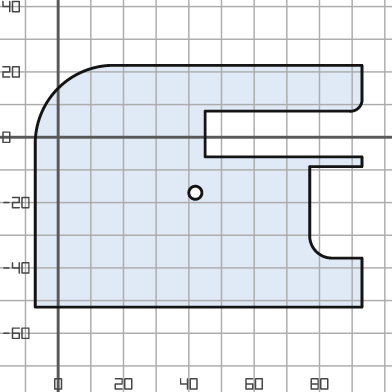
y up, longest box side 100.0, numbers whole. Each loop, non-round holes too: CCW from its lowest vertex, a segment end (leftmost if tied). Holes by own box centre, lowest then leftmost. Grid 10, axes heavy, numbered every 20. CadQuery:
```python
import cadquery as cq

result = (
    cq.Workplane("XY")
    .moveTo(-7.0, -52.0)
    .lineTo(93.0, -52.0)
    .lineTo(93.0, -37.0)
    .lineTo(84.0, -37.0)
    .threePointArc((79.0, -35.0), (77.0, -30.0))
    .lineTo(77.0, -9.0)
    .lineTo(93.0, -9.0)
    .lineTo(93.0, -6.0)
    .lineTo(45.0, -6.0)
    .lineTo(45.0, 8.0)
    .lineTo(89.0, 8.0)
    .threePointArc((92.0, 9.0), (93.0, 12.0))
    .lineTo(93.0, 22.0)
    .lineTo(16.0, 22.0)
    .threePointArc((0.0, 15.0), (-7.0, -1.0))
    .close()
    .moveTo(42.0, -17.0)
    .circle(2.0)
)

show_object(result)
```